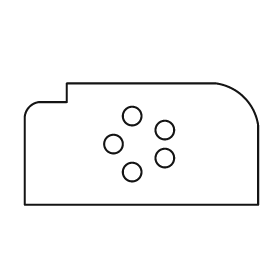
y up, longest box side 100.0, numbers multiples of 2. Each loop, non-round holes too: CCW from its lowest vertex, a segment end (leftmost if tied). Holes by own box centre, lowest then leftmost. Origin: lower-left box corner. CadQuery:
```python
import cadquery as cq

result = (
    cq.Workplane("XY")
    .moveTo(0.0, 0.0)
    .lineTo(100.0, 0.0)
    .lineTo(100.0, 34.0)
    .threePointArc((94.0, 46.0), (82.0, 52.0))
    .lineTo(18.0, 52.0)
    .lineTo(18.0, 44.0)
    .lineTo(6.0, 44.0)
    .threePointArc((2.0, 42.0), (0.0, 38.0))
    .close()
    .moveTo(46.0, 14.0)
    .circle(4.0)
    .moveTo(60.0, 20.0)
    .circle(4.0)
    .moveTo(38.0, 26.0)
    .circle(4.0)
    .moveTo(60.0, 32.0)
    .circle(4.0)
    .moveTo(46.0, 38.0)
    .circle(4.0)
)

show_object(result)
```